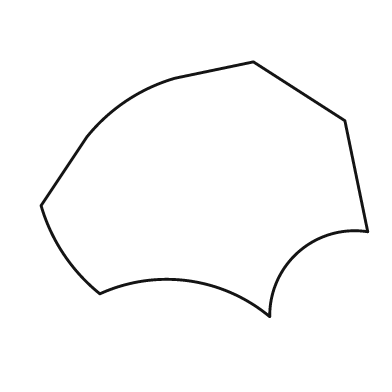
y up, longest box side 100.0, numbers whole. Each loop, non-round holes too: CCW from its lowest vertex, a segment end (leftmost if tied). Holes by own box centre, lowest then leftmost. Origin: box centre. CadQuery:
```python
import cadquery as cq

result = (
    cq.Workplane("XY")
    .moveTo(20.0, -39.0)
    .threePointArc((29.0, -19.0), (50.0, -13.0))
    .lineTo(43.0, 21.0)
    .lineTo(15.0, 39.0)
    .lineTo(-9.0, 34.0)
    .threePointArc((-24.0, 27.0), (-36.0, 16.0))
    .lineTo(-50.0, -5.0)
    .threePointArc((-43.0, -20.0), (-32.0, -32.0))
    .threePointArc((-5.0, -28.0), (20.0, -39.0))
    .close()
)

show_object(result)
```